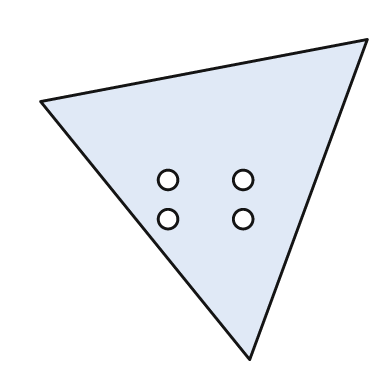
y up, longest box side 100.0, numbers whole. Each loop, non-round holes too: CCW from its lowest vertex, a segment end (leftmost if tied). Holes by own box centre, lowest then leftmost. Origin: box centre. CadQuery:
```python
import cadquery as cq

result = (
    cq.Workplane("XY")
    .moveTo(14.0, -49.0)
    .lineTo(50.0, 49.0)
    .lineTo(-50.0, 30.0)
    .close()
    .moveTo(-11.0, -6.0)
    .circle(3.0)
    .moveTo(12.0, -6.0)
    .circle(3.0)
    .moveTo(-11.0, 6.0)
    .circle(3.0)
    .moveTo(12.0, 6.0)
    .circle(3.0)
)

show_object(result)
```